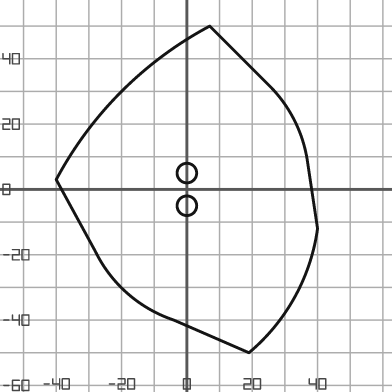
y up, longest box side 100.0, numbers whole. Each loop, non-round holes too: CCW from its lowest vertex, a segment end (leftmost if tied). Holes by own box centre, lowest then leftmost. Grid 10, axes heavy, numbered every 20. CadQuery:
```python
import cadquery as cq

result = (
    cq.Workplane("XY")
    .moveTo(19.0, -50.0)
    .threePointArc((33.0, -33.0), (40.0, -12.0))
    .lineTo(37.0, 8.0)
    .threePointArc((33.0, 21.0), (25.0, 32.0))
    .lineTo(7.0, 50.0)
    .threePointArc((-20.0, 30.0), (-40.0, 3.0))
    .lineTo(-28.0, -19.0)
    .threePointArc((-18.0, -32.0), (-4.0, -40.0))
    .close()
    .moveTo(0.0, -5.0)
    .circle(3.0)
    .moveTo(0.0, 5.0)
    .circle(3.0)
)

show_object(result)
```